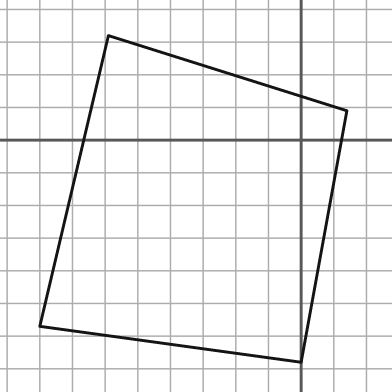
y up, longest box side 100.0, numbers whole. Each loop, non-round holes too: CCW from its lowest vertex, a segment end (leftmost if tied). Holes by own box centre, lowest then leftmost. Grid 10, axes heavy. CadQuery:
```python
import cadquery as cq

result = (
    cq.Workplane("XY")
    .moveTo(0.0, -68.0)
    .lineTo(14.0, 9.0)
    .lineTo(-59.0, 32.0)
    .lineTo(-80.0, -57.0)
    .close()
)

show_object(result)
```